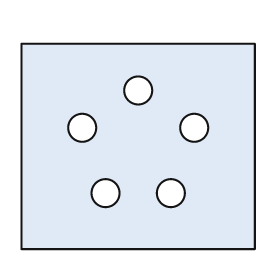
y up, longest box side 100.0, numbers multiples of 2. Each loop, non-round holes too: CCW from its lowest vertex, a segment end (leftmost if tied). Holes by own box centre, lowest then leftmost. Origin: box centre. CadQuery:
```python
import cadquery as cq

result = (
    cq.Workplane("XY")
    .moveTo(-50.0, -44.0)
    .lineTo(50.0, -44.0)
    .lineTo(50.0, 44.0)
    .lineTo(-50.0, 44.0)
    .close()
    .moveTo(-14.0, -20.0)
    .circle(6.0)
    .moveTo(14.0, -20.0)
    .circle(6.0)
    .moveTo(-24.0, 8.0)
    .circle(6.0)
    .moveTo(24.0, 8.0)
    .circle(6.0)
    .moveTo(0.0, 24.0)
    .circle(6.0)
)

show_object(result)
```